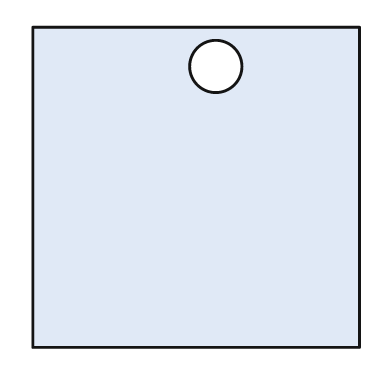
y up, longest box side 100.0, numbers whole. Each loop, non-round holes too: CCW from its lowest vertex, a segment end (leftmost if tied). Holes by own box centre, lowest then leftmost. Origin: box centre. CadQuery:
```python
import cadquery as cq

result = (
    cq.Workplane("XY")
    .moveTo(-50.0, -49.0)
    .lineTo(50.0, -49.0)
    .lineTo(50.0, 49.0)
    .lineTo(-50.0, 49.0)
    .close()
    .moveTo(6.0, 37.0)
    .circle(8.0)
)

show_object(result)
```